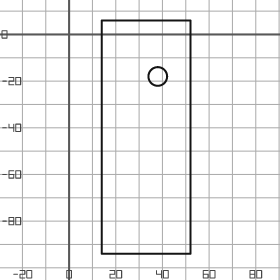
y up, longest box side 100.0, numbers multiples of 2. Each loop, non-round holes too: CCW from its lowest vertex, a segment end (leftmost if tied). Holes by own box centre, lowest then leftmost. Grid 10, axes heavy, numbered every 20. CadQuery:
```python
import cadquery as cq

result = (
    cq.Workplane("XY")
    .moveTo(14.0, -94.0)
    .lineTo(52.0, -94.0)
    .lineTo(52.0, 6.0)
    .lineTo(14.0, 6.0)
    .close()
    .moveTo(38.0, -18.0)
    .circle(4.0)
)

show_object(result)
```